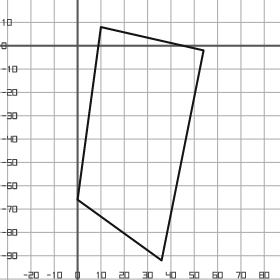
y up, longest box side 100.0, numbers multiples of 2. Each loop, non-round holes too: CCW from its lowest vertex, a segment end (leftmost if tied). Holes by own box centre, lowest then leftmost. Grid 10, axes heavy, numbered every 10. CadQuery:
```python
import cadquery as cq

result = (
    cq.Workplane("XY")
    .moveTo(36.0, -92.0)
    .lineTo(54.0, -2.0)
    .lineTo(10.0, 8.0)
    .lineTo(0.0, -66.0)
    .close()
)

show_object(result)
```